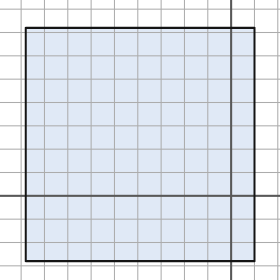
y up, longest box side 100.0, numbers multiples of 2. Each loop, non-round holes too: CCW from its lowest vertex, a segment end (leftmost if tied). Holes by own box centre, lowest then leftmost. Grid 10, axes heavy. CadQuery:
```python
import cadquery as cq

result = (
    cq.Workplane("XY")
    .moveTo(-88.0, -28.0)
    .lineTo(10.0, -28.0)
    .lineTo(10.0, 72.0)
    .lineTo(-88.0, 72.0)
    .close()
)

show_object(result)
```